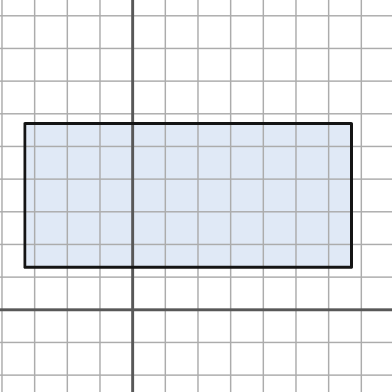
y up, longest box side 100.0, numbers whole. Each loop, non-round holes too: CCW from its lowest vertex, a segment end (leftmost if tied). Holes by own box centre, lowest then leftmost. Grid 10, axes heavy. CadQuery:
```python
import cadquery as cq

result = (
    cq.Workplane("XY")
    .moveTo(-33.0, 13.0)
    .lineTo(67.0, 13.0)
    .lineTo(67.0, 57.0)
    .lineTo(-33.0, 57.0)
    .close()
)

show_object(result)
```